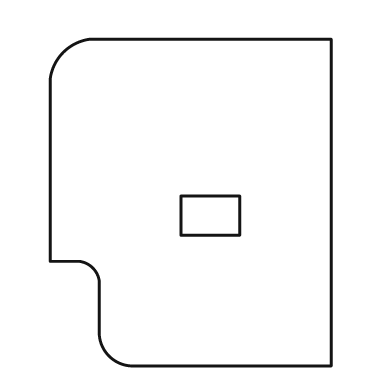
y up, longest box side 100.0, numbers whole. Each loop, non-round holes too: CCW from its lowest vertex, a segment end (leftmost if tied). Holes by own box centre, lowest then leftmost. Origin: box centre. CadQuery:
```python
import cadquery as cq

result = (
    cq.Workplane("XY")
    .moveTo(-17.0, -50.0)
    .lineTo(43.0, -50.0)
    .lineTo(43.0, 50.0)
    .lineTo(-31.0, 50.0)
    .threePointArc((-39.0, 46.0), (-43.0, 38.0))
    .lineTo(-43.0, -18.0)
    .lineTo(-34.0, -18.0)
    .threePointArc((-30.0, -20.0), (-28.0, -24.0))
    .lineTo(-28.0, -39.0)
    .threePointArc((-25.0, -47.0), (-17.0, -50.0))
    .close()
    .moveTo(-3.0, -10.0)
    .lineTo(15.0, -10.0)
    .lineTo(15.0, 2.0)
    .lineTo(-3.0, 2.0)
    .close()
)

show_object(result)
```